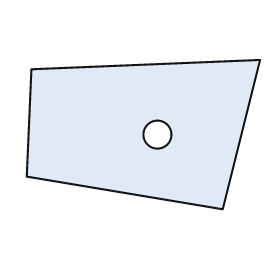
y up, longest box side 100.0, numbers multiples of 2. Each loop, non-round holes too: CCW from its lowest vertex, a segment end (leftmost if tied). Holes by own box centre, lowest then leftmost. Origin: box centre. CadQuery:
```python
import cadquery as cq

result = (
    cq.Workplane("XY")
    .moveTo(34.0, -32.0)
    .lineTo(50.0, 32.0)
    .lineTo(-48.0, 28.0)
    .lineTo(-50.0, -18.0)
    .close()
    .moveTo(6.0, 0.0)
    .circle(6.0)
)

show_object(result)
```